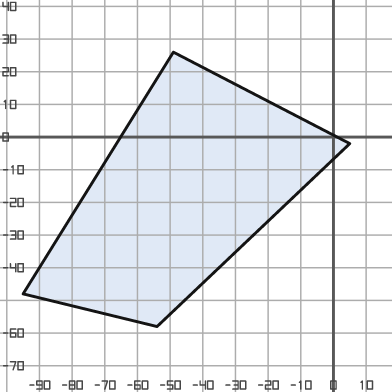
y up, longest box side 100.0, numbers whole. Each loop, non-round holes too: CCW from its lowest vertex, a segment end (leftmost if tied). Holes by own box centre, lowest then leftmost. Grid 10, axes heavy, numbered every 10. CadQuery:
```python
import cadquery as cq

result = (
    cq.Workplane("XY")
    .moveTo(-54.0, -58.0)
    .lineTo(5.0, -2.0)
    .lineTo(-49.0, 26.0)
    .lineTo(-95.0, -48.0)
    .close()
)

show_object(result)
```